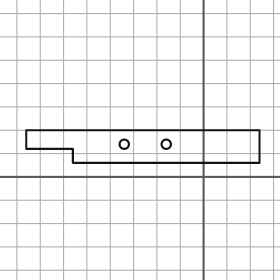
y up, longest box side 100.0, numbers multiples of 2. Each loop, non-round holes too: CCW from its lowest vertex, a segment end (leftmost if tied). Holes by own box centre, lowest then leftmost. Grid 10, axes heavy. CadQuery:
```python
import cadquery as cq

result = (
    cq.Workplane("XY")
    .moveTo(-56.0, 6.0)
    .lineTo(24.0, 6.0)
    .lineTo(24.0, 20.0)
    .lineTo(-76.0, 20.0)
    .lineTo(-76.0, 12.0)
    .lineTo(-56.0, 12.0)
    .close()
    .moveTo(-34.0, 14.0)
    .circle(2.0)
    .moveTo(-16.0, 14.0)
    .circle(2.0)
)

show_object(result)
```